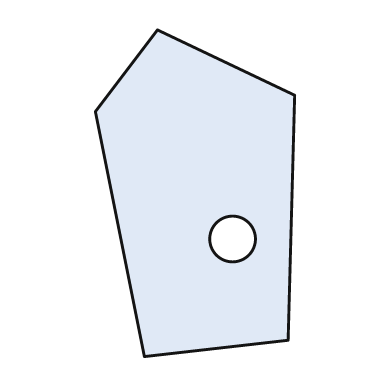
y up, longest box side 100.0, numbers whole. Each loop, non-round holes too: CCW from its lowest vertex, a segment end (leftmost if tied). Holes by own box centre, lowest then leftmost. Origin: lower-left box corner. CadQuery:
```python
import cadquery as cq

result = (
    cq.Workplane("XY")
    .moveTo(15.0, 0.0)
    .lineTo(59.0, 5.0)
    .lineTo(61.0, 80.0)
    .lineTo(19.0, 100.0)
    .lineTo(0.0, 75.0)
    .close()
    .moveTo(42.0, 36.0)
    .circle(7.0)
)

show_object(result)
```